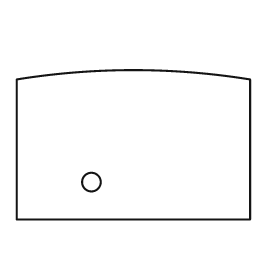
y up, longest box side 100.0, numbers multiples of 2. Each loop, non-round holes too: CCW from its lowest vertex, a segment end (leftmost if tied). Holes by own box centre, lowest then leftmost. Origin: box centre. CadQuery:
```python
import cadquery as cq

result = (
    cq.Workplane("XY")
    .moveTo(-50.0, -32.0)
    .lineTo(50.0, -32.0)
    .lineTo(50.0, 28.0)
    .threePointArc((0.0, 32.0), (-50.0, 28.0))
    .close()
    .moveTo(-18.0, -16.0)
    .circle(4.0)
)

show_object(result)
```